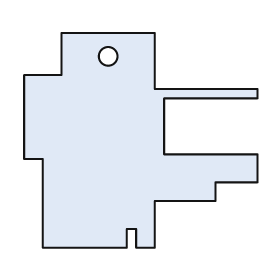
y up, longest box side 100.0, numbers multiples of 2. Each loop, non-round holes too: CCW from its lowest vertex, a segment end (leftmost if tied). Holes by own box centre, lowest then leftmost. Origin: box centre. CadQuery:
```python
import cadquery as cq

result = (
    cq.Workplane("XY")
    .moveTo(-42.0, -46.0)
    .lineTo(-6.0, -46.0)
    .lineTo(-6.0, -38.0)
    .lineTo(-2.0, -38.0)
    .lineTo(-2.0, -46.0)
    .lineTo(6.0, -46.0)
    .lineTo(6.0, -26.0)
    .lineTo(32.0, -26.0)
    .lineTo(32.0, -18.0)
    .lineTo(50.0, -18.0)
    .lineTo(50.0, -6.0)
    .lineTo(10.0, -6.0)
    .lineTo(10.0, 18.0)
    .lineTo(50.0, 18.0)
    .lineTo(50.0, 22.0)
    .lineTo(6.0, 22.0)
    .lineTo(6.0, 46.0)
    .lineTo(-34.0, 46.0)
    .lineTo(-34.0, 28.0)
    .lineTo(-50.0, 28.0)
    .lineTo(-50.0, -8.0)
    .lineTo(-42.0, -8.0)
    .close()
    .moveTo(-14.0, 36.0)
    .circle(4.0)
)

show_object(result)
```